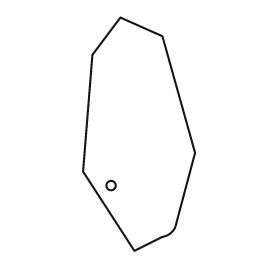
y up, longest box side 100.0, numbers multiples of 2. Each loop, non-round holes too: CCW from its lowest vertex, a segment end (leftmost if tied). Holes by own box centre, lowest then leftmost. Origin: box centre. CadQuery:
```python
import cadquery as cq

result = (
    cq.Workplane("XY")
    .moveTo(-2.0, -50.0)
    .lineTo(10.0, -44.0)
    .threePointArc((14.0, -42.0), (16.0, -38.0))
    .lineTo(24.0, -8.0)
    .lineTo(10.0, 42.0)
    .lineTo(-8.0, 50.0)
    .lineTo(-20.0, 34.0)
    .lineTo(-24.0, -16.0)
    .close()
    .moveTo(-12.0, -22.0)
    .circle(2.0)
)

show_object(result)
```